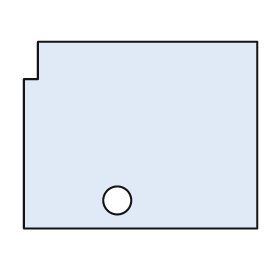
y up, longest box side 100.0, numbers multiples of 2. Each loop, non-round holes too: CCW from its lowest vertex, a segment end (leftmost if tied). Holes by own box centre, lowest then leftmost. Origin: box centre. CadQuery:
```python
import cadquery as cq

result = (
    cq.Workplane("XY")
    .moveTo(-50.0, -40.0)
    .lineTo(50.0, -40.0)
    .lineTo(50.0, 40.0)
    .lineTo(-44.0, 40.0)
    .lineTo(-44.0, 24.0)
    .lineTo(-50.0, 24.0)
    .close()
    .moveTo(-10.0, -28.0)
    .circle(6.0)
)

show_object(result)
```